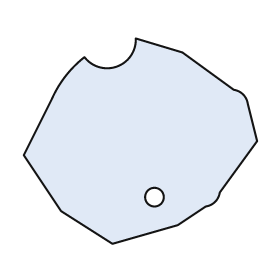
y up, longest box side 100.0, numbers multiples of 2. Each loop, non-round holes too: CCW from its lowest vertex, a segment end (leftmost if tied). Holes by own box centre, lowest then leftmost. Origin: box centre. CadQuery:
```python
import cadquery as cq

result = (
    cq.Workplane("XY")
    .moveTo(-12.0, -44.0)
    .lineTo(16.0, -36.0)
    .lineTo(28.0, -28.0)
    .threePointArc((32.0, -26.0), (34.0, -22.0))
    .lineTo(50.0, 0.0)
    .lineTo(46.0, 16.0)
    .threePointArc((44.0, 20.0), (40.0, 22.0))
    .lineTo(18.0, 38.0)
    .lineTo(-2.0, 44.0)
    .threePointArc((-10.0, 32.0), (-24.0, 36.0))
    .threePointArc((-32.0, 28.0), (-38.0, 18.0))
    .lineTo(-50.0, -6.0)
    .lineTo(-34.0, -30.0)
    .close()
    .moveTo(6.0, -24.0)
    .circle(4.0)
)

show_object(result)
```